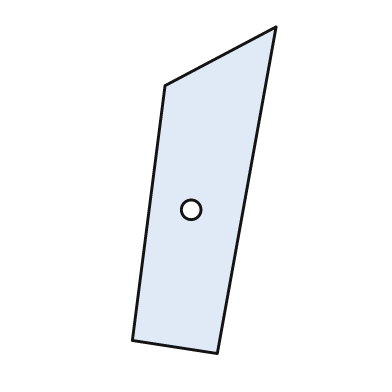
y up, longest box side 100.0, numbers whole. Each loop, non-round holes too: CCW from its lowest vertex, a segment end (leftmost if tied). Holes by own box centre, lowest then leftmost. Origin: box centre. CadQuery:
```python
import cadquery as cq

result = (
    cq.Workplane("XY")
    .moveTo(4.0, -50.0)
    .lineTo(22.0, 50.0)
    .lineTo(-12.0, 32.0)
    .lineTo(-22.0, -46.0)
    .close()
    .moveTo(-4.0, -6.0)
    .circle(3.0)
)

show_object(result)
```